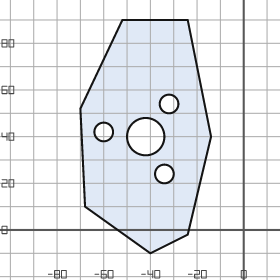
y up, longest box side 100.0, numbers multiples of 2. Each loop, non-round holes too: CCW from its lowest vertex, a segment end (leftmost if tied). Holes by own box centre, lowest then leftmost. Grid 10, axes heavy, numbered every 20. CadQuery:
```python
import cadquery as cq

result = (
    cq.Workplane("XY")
    .moveTo(-40.0, -10.0)
    .lineTo(-24.0, -2.0)
    .lineTo(-14.0, 40.0)
    .lineTo(-24.0, 90.0)
    .lineTo(-52.0, 90.0)
    .lineTo(-70.0, 52.0)
    .lineTo(-68.0, 10.0)
    .close()
    .moveTo(-34.0, 24.0)
    .circle(4.0)
    .moveTo(-42.0, 40.0)
    .circle(8.0)
    .moveTo(-60.0, 42.0)
    .circle(4.0)
    .moveTo(-32.0, 54.0)
    .circle(4.0)
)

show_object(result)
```